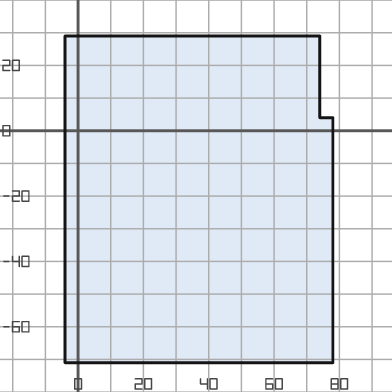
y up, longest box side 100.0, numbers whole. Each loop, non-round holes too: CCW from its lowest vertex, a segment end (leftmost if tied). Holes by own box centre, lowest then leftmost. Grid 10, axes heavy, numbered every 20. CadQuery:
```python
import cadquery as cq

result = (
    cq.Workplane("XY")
    .moveTo(-4.0, -71.0)
    .lineTo(78.0, -71.0)
    .lineTo(78.0, 4.0)
    .lineTo(74.0, 4.0)
    .lineTo(74.0, 29.0)
    .lineTo(-4.0, 29.0)
    .close()
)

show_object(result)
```